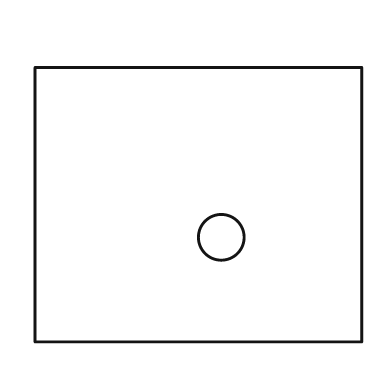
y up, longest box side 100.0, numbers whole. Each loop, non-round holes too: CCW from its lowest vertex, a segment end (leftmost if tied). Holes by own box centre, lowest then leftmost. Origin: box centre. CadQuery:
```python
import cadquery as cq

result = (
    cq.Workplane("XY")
    .moveTo(-50.0, -42.0)
    .lineTo(50.0, -42.0)
    .lineTo(50.0, 42.0)
    .lineTo(-50.0, 42.0)
    .close()
    .moveTo(7.0, -10.0)
    .circle(7.0)
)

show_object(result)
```